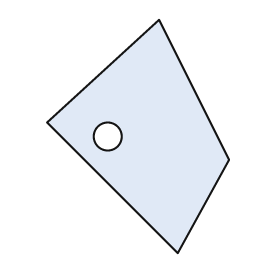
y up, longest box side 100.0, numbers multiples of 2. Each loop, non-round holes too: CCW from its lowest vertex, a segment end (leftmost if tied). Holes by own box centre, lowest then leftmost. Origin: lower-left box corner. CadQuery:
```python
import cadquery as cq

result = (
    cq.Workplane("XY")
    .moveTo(56.0, 0.0)
    .lineTo(78.0, 40.0)
    .lineTo(48.0, 100.0)
    .lineTo(0.0, 56.0)
    .close()
    .moveTo(26.0, 50.0)
    .circle(6.0)
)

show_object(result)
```